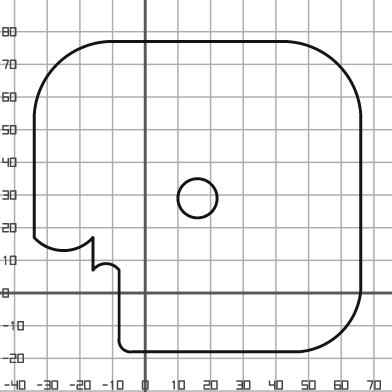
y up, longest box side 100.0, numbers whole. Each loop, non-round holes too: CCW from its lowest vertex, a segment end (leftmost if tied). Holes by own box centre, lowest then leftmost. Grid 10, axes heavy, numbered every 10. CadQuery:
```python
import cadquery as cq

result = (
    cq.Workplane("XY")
    .moveTo(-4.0, -18.0)
    .lineTo(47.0, -18.0)
    .threePointArc((60.0, -12.0), (66.0, 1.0))
    .lineTo(66.0, 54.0)
    .threePointArc((59.0, 70.0), (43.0, 77.0))
    .lineTo(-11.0, 77.0)
    .threePointArc((-27.0, 70.0), (-34.0, 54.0))
    .lineTo(-34.0, 17.0)
    .threePointArc((-25.0, 13.0), (-16.0, 17.0))
    .lineTo(-16.0, 7.0)
    .threePointArc((-12.0, 9.0), (-8.0, 7.0))
    .lineTo(-8.0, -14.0)
    .threePointArc((-7.0, -17.0), (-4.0, -18.0))
    .close()
    .moveTo(16.0, 29.0)
    .circle(6.0)
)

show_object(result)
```